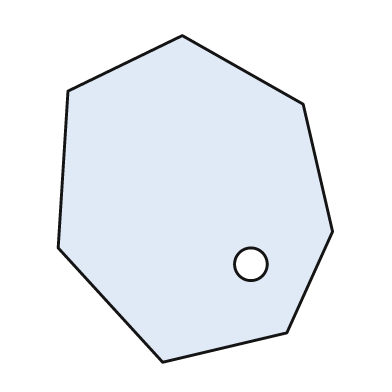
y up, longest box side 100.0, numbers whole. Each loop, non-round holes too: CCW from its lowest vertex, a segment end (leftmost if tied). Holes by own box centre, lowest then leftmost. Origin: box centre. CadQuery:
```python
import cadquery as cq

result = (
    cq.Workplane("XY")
    .moveTo(-10.0, -50.0)
    .lineTo(28.0, -41.0)
    .lineTo(42.0, -10.0)
    .lineTo(33.0, 29.0)
    .lineTo(-4.0, 50.0)
    .lineTo(-39.0, 33.0)
    .lineTo(-42.0, -15.0)
    .close()
    .moveTo(17.0, -20.0)
    .circle(5.0)
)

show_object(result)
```